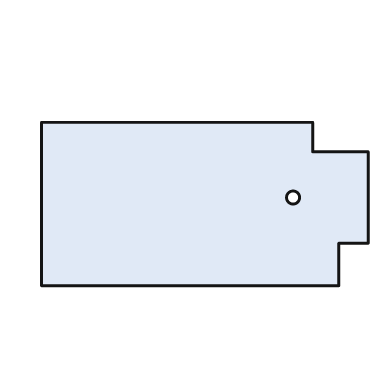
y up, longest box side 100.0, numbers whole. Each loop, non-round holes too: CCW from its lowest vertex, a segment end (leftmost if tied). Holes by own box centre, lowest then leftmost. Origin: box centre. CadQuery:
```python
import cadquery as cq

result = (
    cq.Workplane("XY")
    .moveTo(-50.0, -25.0)
    .lineTo(41.0, -25.0)
    .lineTo(41.0, -12.0)
    .lineTo(50.0, -12.0)
    .lineTo(50.0, 16.0)
    .lineTo(33.0, 16.0)
    .lineTo(33.0, 25.0)
    .lineTo(-50.0, 25.0)
    .close()
    .moveTo(27.0, 2.0)
    .circle(2.0)
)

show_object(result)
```